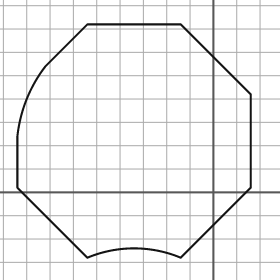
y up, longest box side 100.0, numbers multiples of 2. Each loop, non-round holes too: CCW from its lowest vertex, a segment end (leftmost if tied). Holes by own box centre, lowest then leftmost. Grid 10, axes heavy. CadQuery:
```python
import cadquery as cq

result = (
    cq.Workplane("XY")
    .moveTo(-54.0, -28.0)
    .threePointArc((-34.0, -24.0), (-14.0, -28.0))
    .lineTo(16.0, 2.0)
    .lineTo(16.0, 42.0)
    .lineTo(-14.0, 72.0)
    .lineTo(-54.0, 72.0)
    .lineTo(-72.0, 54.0)
    .threePointArc((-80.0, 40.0), (-84.0, 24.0))
    .lineTo(-84.0, 2.0)
    .close()
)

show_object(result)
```